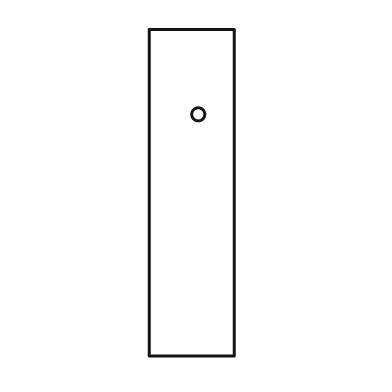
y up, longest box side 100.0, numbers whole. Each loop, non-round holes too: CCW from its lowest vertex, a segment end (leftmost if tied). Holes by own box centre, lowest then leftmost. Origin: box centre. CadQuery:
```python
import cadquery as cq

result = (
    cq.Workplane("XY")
    .moveTo(-13.0, -50.0)
    .lineTo(13.0, -50.0)
    .lineTo(13.0, 50.0)
    .lineTo(-13.0, 50.0)
    .close()
    .moveTo(2.0, 24.0)
    .circle(2.0)
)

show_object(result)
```